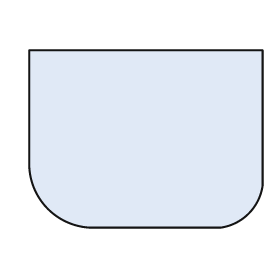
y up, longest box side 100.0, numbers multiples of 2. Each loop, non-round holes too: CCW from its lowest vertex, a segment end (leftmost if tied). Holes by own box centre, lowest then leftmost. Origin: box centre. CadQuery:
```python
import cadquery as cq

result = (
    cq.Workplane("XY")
    .moveTo(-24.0, -38.0)
    .lineTo(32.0, -38.0)
    .threePointArc((44.0, -32.0), (50.0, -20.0))
    .lineTo(50.0, 38.0)
    .lineTo(-50.0, 38.0)
    .lineTo(-50.0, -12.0)
    .threePointArc((-42.0, -30.0), (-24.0, -38.0))
    .close()
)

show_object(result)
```